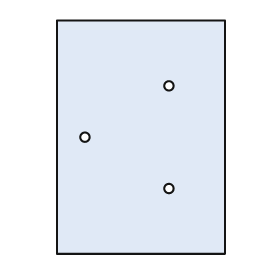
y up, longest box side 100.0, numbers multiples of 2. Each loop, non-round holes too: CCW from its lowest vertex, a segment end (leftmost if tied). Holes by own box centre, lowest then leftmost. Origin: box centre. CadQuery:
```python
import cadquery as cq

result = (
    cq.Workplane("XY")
    .moveTo(-36.0, -50.0)
    .lineTo(36.0, -50.0)
    .lineTo(36.0, 50.0)
    .lineTo(-36.0, 50.0)
    .close()
    .moveTo(12.0, -22.0)
    .circle(2.0)
    .moveTo(-24.0, 0.0)
    .circle(2.0)
    .moveTo(12.0, 22.0)
    .circle(2.0)
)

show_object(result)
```